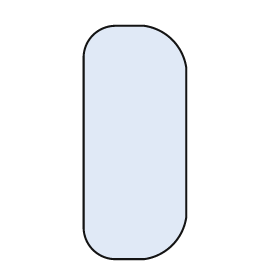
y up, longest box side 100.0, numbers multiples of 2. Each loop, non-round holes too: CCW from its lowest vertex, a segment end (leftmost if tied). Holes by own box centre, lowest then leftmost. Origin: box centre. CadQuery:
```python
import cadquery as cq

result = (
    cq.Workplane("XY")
    .moveTo(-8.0, -50.0)
    .lineTo(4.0, -50.0)
    .threePointArc((16.0, -44.0), (22.0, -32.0))
    .lineTo(22.0, 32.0)
    .threePointArc((16.0, 44.0), (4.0, 50.0))
    .lineTo(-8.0, 50.0)
    .threePointArc((-18.0, 46.0), (-22.0, 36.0))
    .lineTo(-22.0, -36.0)
    .threePointArc((-18.0, -46.0), (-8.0, -50.0))
    .close()
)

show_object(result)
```